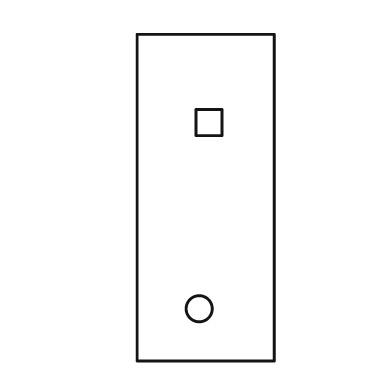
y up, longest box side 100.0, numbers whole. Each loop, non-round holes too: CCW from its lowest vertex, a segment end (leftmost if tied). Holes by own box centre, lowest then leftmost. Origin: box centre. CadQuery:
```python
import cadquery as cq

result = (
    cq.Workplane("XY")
    .moveTo(-21.0, -50.0)
    .lineTo(21.0, -50.0)
    .lineTo(21.0, 50.0)
    .lineTo(-21.0, 50.0)
    .close()
    .moveTo(-2.0, -34.0)
    .circle(4.0)
    .moveTo(-3.0, 19.0)
    .lineTo(5.0, 19.0)
    .lineTo(5.0, 27.0)
    .lineTo(-3.0, 27.0)
    .close()
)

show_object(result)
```